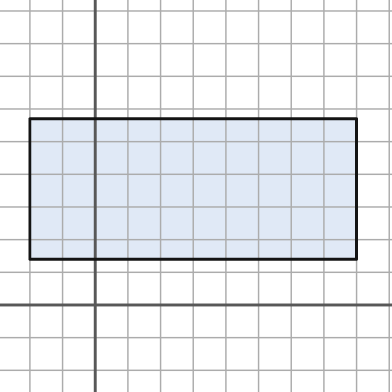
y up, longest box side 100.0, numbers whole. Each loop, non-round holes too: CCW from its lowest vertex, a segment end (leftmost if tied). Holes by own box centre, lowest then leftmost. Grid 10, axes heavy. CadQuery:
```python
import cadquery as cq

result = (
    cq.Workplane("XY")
    .moveTo(-20.0, 14.0)
    .lineTo(80.0, 14.0)
    .lineTo(80.0, 57.0)
    .lineTo(-20.0, 57.0)
    .close()
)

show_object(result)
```